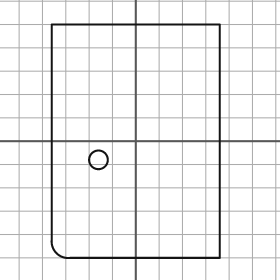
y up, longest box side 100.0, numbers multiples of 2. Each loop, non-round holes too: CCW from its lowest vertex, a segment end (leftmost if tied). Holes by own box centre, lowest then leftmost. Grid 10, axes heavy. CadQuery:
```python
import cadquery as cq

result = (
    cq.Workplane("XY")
    .moveTo(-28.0, -50.0)
    .lineTo(36.0, -50.0)
    .lineTo(36.0, 50.0)
    .lineTo(-36.0, 50.0)
    .lineTo(-36.0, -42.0)
    .threePointArc((-34.0, -48.0), (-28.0, -50.0))
    .close()
    .moveTo(-16.0, -8.0)
    .circle(4.0)
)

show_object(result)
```